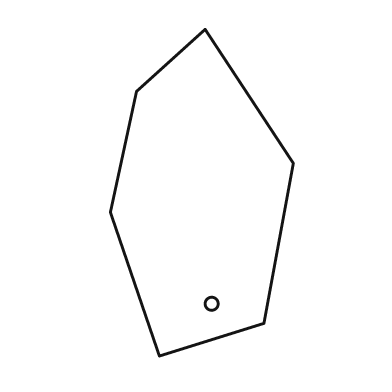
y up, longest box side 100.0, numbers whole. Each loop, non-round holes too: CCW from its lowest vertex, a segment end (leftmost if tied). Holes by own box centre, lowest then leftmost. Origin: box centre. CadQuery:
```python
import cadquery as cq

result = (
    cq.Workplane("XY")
    .moveTo(-13.0, -50.0)
    .lineTo(19.0, -40.0)
    .lineTo(28.0, 9.0)
    .lineTo(1.0, 50.0)
    .lineTo(-20.0, 31.0)
    .lineTo(-28.0, -6.0)
    .close()
    .moveTo(3.0, -34.0)
    .circle(2.0)
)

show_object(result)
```